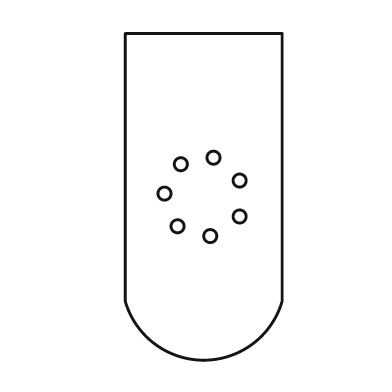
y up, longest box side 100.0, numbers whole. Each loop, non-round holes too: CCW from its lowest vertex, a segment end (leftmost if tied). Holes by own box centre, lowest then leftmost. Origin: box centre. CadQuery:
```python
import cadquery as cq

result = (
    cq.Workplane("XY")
    .moveTo(-24.0, -32.0)
    .threePointArc((0.0, -50.0), (24.0, -32.0))
    .lineTo(24.0, 50.0)
    .lineTo(-24.0, 50.0)
    .close()
    .moveTo(2.0, -12.0)
    .circle(2.0)
    .moveTo(-8.0, -9.0)
    .circle(2.0)
    .moveTo(11.0, -6.0)
    .circle(2.0)
    .moveTo(-12.0, 1.0)
    .circle(2.0)
    .moveTo(11.0, 5.0)
    .circle(2.0)
    .moveTo(-7.0, 10.0)
    .circle(2.0)
    .moveTo(3.0, 12.0)
    .circle(2.0)
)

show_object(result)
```